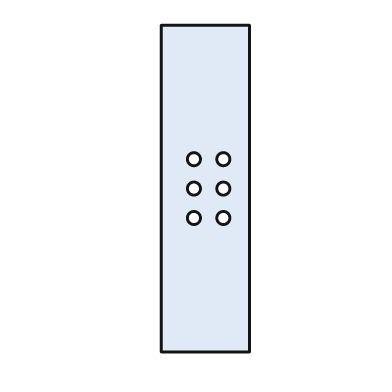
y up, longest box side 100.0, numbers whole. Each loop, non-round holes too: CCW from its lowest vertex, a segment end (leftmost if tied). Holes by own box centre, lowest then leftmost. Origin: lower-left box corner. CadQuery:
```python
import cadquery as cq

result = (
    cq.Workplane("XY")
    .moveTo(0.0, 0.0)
    .lineTo(27.0, 0.0)
    .lineTo(27.0, 100.0)
    .lineTo(0.0, 100.0)
    .close()
    .moveTo(10.0, 41.0)
    .circle(2.0)
    .moveTo(19.0, 41.0)
    .circle(2.0)
    .moveTo(10.0, 50.0)
    .circle(2.0)
    .moveTo(19.0, 50.0)
    .circle(2.0)
    .moveTo(10.0, 59.0)
    .circle(2.0)
    .moveTo(19.0, 59.0)
    .circle(2.0)
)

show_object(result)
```